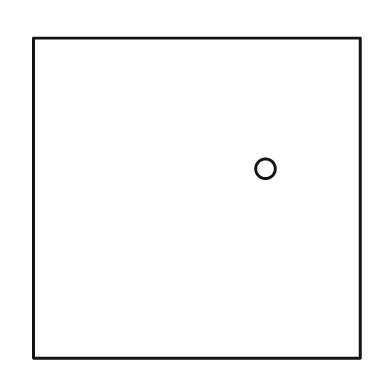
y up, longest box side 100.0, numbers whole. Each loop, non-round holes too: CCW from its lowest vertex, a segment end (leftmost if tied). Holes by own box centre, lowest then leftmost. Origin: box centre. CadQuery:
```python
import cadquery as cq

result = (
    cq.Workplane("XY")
    .moveTo(-50.0, -49.0)
    .lineTo(50.0, -49.0)
    .lineTo(50.0, 49.0)
    .lineTo(-50.0, 49.0)
    .close()
    .moveTo(21.0, 9.0)
    .circle(3.0)
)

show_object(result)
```